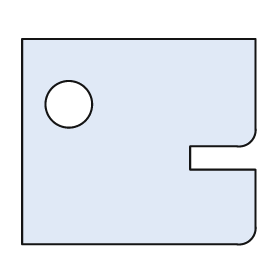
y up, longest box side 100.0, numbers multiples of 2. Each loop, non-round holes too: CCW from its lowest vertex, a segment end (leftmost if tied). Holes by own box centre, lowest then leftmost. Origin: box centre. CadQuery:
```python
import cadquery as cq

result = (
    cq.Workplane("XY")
    .moveTo(-50.0, -44.0)
    .lineTo(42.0, -44.0)
    .threePointArc((48.0, -42.0), (50.0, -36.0))
    .lineTo(50.0, -12.0)
    .lineTo(22.0, -12.0)
    .lineTo(22.0, -2.0)
    .lineTo(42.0, -2.0)
    .threePointArc((48.0, 0.0), (50.0, 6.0))
    .lineTo(50.0, 44.0)
    .lineTo(-50.0, 44.0)
    .close()
    .moveTo(-30.0, 16.0)
    .circle(10.0)
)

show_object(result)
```